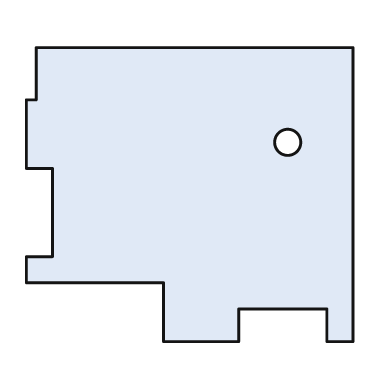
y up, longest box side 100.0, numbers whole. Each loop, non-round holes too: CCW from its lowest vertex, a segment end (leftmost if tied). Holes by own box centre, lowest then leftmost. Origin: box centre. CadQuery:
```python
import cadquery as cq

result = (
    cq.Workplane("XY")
    .moveTo(-8.0, -45.0)
    .lineTo(15.0, -45.0)
    .lineTo(15.0, -35.0)
    .lineTo(42.0, -35.0)
    .lineTo(42.0, -45.0)
    .lineTo(50.0, -45.0)
    .lineTo(50.0, 45.0)
    .lineTo(-47.0, 45.0)
    .lineTo(-47.0, 29.0)
    .lineTo(-50.0, 29.0)
    .lineTo(-50.0, 8.0)
    .lineTo(-42.0, 8.0)
    .lineTo(-42.0, -19.0)
    .lineTo(-50.0, -19.0)
    .lineTo(-50.0, -27.0)
    .lineTo(-8.0, -27.0)
    .close()
    .moveTo(30.0, 16.0)
    .circle(4.0)
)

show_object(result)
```